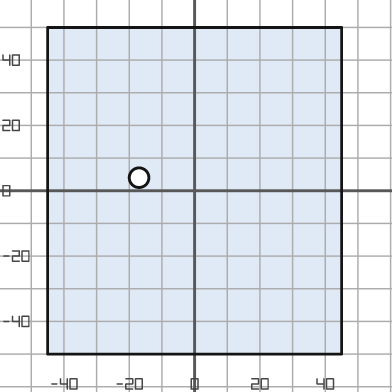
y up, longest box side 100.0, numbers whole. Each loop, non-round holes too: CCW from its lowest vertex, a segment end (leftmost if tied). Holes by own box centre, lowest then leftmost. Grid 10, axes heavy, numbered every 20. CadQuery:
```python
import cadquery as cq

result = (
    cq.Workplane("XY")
    .moveTo(-45.0, -50.0)
    .lineTo(45.0, -50.0)
    .lineTo(45.0, 50.0)
    .lineTo(-45.0, 50.0)
    .close()
    .moveTo(-17.0, 4.0)
    .circle(3.0)
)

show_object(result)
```